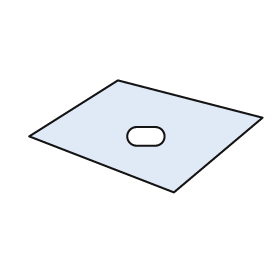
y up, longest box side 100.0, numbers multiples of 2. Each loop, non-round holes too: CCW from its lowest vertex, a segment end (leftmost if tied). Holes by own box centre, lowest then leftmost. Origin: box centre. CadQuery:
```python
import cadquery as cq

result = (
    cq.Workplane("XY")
    .moveTo(12.0, -24.0)
    .lineTo(50.0, 8.0)
    .lineTo(-12.0, 24.0)
    .lineTo(-50.0, 0.0)
    .close()
    .moveTo(-4.0, -4.0)
    .lineTo(4.0, -4.0)
    .threePointArc((8.0, 0.0), (4.0, 4.0))
    .lineTo(-4.0, 4.0)
    .threePointArc((-8.0, 0.0), (-4.0, -4.0))
    .close()
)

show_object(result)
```